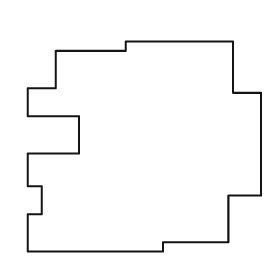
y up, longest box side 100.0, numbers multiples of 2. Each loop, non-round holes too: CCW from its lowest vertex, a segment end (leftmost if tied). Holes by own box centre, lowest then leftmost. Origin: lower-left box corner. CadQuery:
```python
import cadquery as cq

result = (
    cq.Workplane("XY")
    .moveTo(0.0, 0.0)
    .lineTo(58.0, 0.0)
    .lineTo(58.0, 4.0)
    .lineTo(86.0, 4.0)
    .lineTo(86.0, 24.0)
    .lineTo(100.0, 24.0)
    .lineTo(100.0, 68.0)
    .lineTo(88.0, 68.0)
    .lineTo(88.0, 90.0)
    .lineTo(42.0, 90.0)
    .lineTo(42.0, 86.0)
    .lineTo(12.0, 86.0)
    .lineTo(12.0, 70.0)
    .lineTo(0.0, 70.0)
    .lineTo(0.0, 58.0)
    .lineTo(22.0, 58.0)
    .lineTo(22.0, 42.0)
    .lineTo(0.0, 42.0)
    .lineTo(0.0, 28.0)
    .lineTo(6.0, 28.0)
    .lineTo(6.0, 16.0)
    .lineTo(0.0, 16.0)
    .close()
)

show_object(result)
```